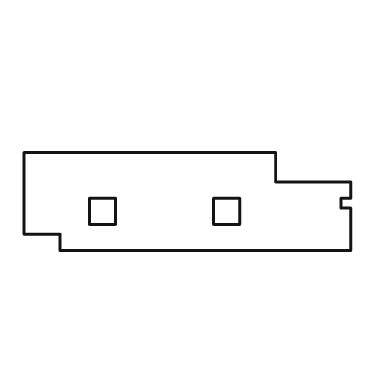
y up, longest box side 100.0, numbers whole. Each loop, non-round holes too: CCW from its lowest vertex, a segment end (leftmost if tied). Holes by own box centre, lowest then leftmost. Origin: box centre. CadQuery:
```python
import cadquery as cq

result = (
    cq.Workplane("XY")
    .moveTo(-39.0, -15.0)
    .lineTo(50.0, -15.0)
    .lineTo(50.0, -2.0)
    .lineTo(47.0, -2.0)
    .lineTo(47.0, 1.0)
    .lineTo(50.0, 1.0)
    .lineTo(50.0, 6.0)
    .lineTo(27.0, 6.0)
    .lineTo(27.0, 15.0)
    .lineTo(-50.0, 15.0)
    .lineTo(-50.0, -10.0)
    .lineTo(-39.0, -10.0)
    .close()
    .moveTo(-30.0, -7.0)
    .lineTo(-22.0, -7.0)
    .lineTo(-22.0, 1.0)
    .lineTo(-30.0, 1.0)
    .close()
    .moveTo(8.0, -7.0)
    .lineTo(16.0, -7.0)
    .lineTo(16.0, 1.0)
    .lineTo(8.0, 1.0)
    .close()
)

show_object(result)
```